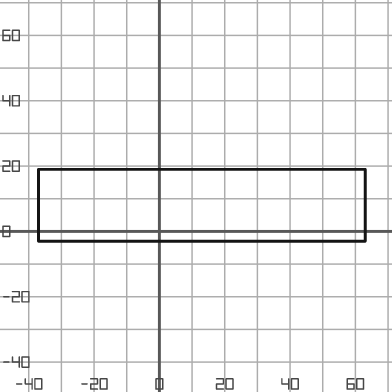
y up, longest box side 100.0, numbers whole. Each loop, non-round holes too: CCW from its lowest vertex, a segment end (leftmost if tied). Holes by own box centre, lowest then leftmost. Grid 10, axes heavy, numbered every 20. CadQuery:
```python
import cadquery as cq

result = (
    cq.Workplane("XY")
    .moveTo(-37.0, -3.0)
    .lineTo(63.0, -3.0)
    .lineTo(63.0, 19.0)
    .lineTo(-37.0, 19.0)
    .close()
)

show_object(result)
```